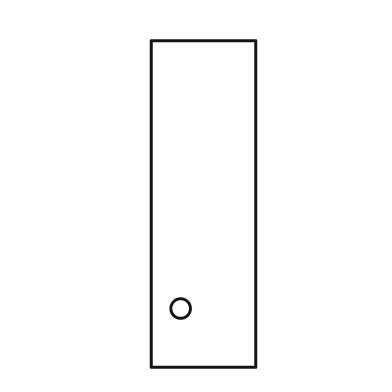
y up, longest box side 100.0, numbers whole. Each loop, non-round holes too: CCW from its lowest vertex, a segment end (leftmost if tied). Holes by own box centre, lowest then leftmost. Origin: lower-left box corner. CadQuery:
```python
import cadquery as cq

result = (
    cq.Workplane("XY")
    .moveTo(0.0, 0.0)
    .lineTo(32.0, 0.0)
    .lineTo(32.0, 100.0)
    .lineTo(0.0, 100.0)
    .close()
    .moveTo(9.0, 18.0)
    .circle(3.0)
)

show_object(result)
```